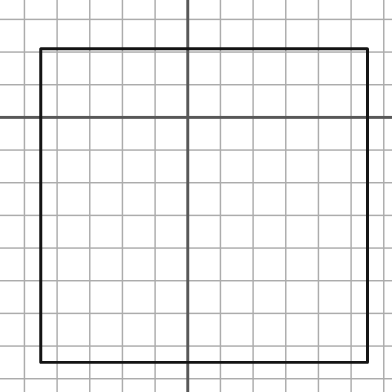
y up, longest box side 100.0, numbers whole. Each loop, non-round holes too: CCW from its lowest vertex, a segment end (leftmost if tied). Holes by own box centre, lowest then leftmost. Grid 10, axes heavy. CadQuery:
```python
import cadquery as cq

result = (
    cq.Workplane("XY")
    .moveTo(-45.0, -75.0)
    .lineTo(55.0, -75.0)
    .lineTo(55.0, 21.0)
    .lineTo(-45.0, 21.0)
    .close()
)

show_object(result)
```